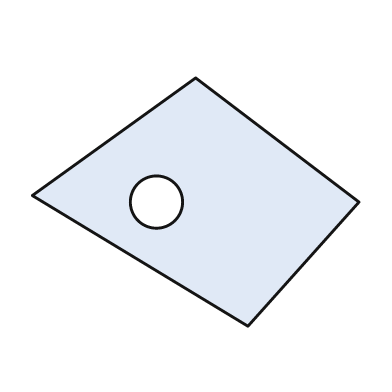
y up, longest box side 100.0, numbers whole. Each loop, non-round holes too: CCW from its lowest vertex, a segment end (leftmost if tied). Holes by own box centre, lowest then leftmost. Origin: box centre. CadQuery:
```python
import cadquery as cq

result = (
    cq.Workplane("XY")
    .moveTo(16.0, -38.0)
    .lineTo(50.0, 0.0)
    .lineTo(0.0, 38.0)
    .lineTo(-50.0, 2.0)
    .close()
    .moveTo(-12.0, 0.0)
    .circle(8.0)
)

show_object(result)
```